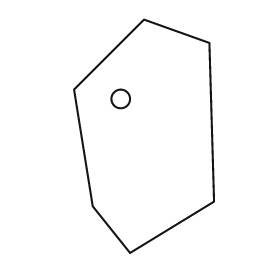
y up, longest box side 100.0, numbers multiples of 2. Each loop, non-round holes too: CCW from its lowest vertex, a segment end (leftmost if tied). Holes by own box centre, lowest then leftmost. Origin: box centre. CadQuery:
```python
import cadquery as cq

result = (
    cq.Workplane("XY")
    .moveTo(-6.0, -50.0)
    .lineTo(30.0, -28.0)
    .lineTo(28.0, 40.0)
    .lineTo(0.0, 50.0)
    .lineTo(-30.0, 20.0)
    .lineTo(-22.0, -30.0)
    .close()
    .moveTo(-10.0, 16.0)
    .circle(4.0)
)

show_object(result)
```